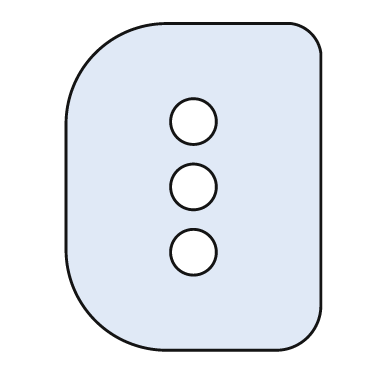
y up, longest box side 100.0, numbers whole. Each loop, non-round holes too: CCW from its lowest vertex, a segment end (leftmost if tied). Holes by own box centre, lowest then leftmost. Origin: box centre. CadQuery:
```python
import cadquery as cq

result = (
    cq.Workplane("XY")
    .moveTo(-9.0, -50.0)
    .lineTo(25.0, -50.0)
    .threePointArc((35.0, -46.0), (39.0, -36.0))
    .lineTo(39.0, 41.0)
    .threePointArc((36.0, 47.0), (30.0, 50.0))
    .lineTo(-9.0, 50.0)
    .threePointArc((-30.0, 41.0), (-39.0, 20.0))
    .lineTo(-39.0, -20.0)
    .threePointArc((-30.0, -41.0), (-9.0, -50.0))
    .close()
    .moveTo(0.0, -20.0)
    .circle(7.0)
    .moveTo(0.0, 0.0)
    .circle(7.0)
    .moveTo(0.0, 20.0)
    .circle(7.0)
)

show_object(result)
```